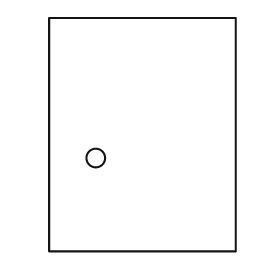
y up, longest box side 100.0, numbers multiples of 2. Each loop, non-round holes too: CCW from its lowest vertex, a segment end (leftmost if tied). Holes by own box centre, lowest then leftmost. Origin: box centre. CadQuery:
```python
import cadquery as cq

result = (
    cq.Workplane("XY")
    .moveTo(-40.0, -50.0)
    .lineTo(40.0, -50.0)
    .lineTo(40.0, 50.0)
    .lineTo(-40.0, 50.0)
    .close()
    .moveTo(-20.0, -10.0)
    .circle(4.0)
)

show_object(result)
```